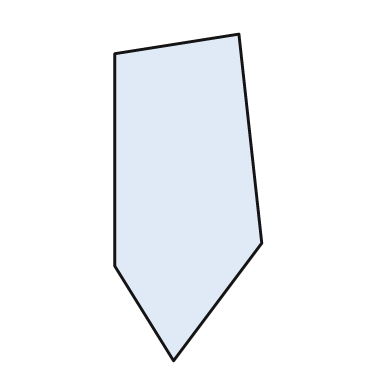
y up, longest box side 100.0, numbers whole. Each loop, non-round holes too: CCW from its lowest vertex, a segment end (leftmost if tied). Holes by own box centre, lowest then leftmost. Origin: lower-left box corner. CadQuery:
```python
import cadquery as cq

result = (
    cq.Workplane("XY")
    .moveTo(18.0, 0.0)
    .lineTo(45.0, 36.0)
    .lineTo(38.0, 100.0)
    .lineTo(0.0, 94.0)
    .lineTo(0.0, 29.0)
    .close()
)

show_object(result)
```